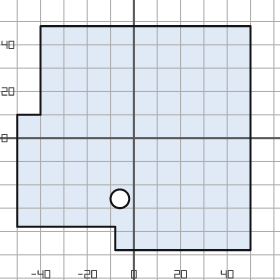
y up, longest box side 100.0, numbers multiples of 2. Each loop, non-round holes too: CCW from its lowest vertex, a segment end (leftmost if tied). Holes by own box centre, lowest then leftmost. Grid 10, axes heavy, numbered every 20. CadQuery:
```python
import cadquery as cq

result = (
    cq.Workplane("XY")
    .moveTo(-8.0, -48.0)
    .lineTo(50.0, -48.0)
    .lineTo(50.0, 48.0)
    .lineTo(-40.0, 48.0)
    .lineTo(-40.0, 10.0)
    .lineTo(-50.0, 10.0)
    .lineTo(-50.0, -38.0)
    .lineTo(-8.0, -38.0)
    .close()
    .moveTo(-6.0, -26.0)
    .circle(4.0)
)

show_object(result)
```